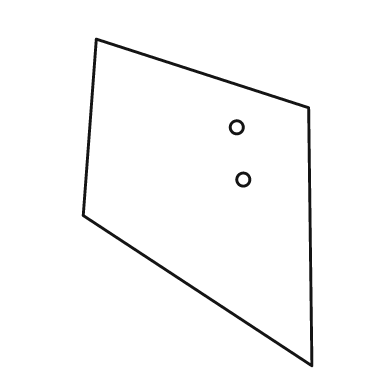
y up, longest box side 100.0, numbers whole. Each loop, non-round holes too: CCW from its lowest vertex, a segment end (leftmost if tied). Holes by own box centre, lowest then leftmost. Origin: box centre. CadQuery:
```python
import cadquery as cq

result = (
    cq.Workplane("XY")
    .moveTo(35.0, -50.0)
    .lineTo(34.0, 29.0)
    .lineTo(-31.0, 50.0)
    .lineTo(-35.0, -4.0)
    .close()
    .moveTo(14.0, 7.0)
    .circle(2.0)
    .moveTo(12.0, 23.0)
    .circle(2.0)
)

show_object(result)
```